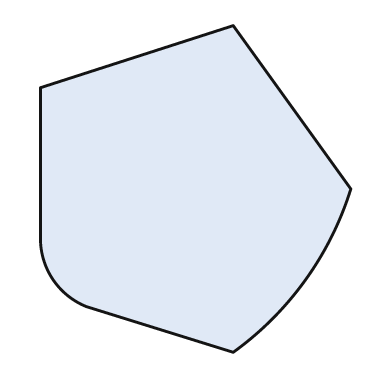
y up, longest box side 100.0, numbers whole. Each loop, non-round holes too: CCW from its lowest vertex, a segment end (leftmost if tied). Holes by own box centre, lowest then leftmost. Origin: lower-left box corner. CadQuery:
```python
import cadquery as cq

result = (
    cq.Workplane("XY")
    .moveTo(59.0, 0.0)
    .threePointArc((81.0, 22.0), (95.0, 50.0))
    .lineTo(59.0, 100.0)
    .lineTo(0.0, 81.0)
    .lineTo(0.0, 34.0)
    .threePointArc((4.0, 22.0), (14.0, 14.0))
    .close()
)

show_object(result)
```